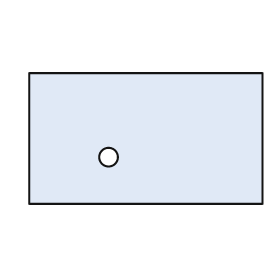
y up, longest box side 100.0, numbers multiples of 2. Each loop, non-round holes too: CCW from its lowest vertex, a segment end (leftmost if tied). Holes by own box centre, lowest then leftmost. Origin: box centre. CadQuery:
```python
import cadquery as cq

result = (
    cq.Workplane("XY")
    .moveTo(-50.0, -28.0)
    .lineTo(50.0, -28.0)
    .lineTo(50.0, 28.0)
    .lineTo(-50.0, 28.0)
    .close()
    .moveTo(-16.0, -8.0)
    .circle(4.0)
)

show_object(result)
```